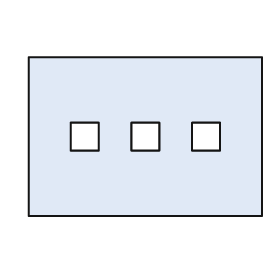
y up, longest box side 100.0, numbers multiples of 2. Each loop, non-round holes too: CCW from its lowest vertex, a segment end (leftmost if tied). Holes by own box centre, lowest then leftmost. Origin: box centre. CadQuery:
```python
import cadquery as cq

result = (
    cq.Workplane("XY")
    .moveTo(-50.0, -34.0)
    .lineTo(50.0, -34.0)
    .lineTo(50.0, 34.0)
    .lineTo(-50.0, 34.0)
    .close()
    .moveTo(-32.0, -6.0)
    .lineTo(-20.0, -6.0)
    .lineTo(-20.0, 6.0)
    .lineTo(-32.0, 6.0)
    .close()
    .moveTo(-6.0, -6.0)
    .lineTo(6.0, -6.0)
    .lineTo(6.0, 6.0)
    .lineTo(-6.0, 6.0)
    .close()
    .moveTo(20.0, -6.0)
    .lineTo(32.0, -6.0)
    .lineTo(32.0, 6.0)
    .lineTo(20.0, 6.0)
    .close()
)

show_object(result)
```